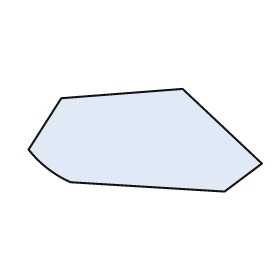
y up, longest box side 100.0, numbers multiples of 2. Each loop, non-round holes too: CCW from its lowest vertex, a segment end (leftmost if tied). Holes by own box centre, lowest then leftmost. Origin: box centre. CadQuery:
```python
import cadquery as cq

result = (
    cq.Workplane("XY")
    .moveTo(34.0, -22.0)
    .lineTo(50.0, -10.0)
    .lineTo(16.0, 22.0)
    .lineTo(-36.0, 18.0)
    .lineTo(-50.0, -4.0)
    .threePointArc((-42.0, -12.0), (-32.0, -18.0))
    .close()
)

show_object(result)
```